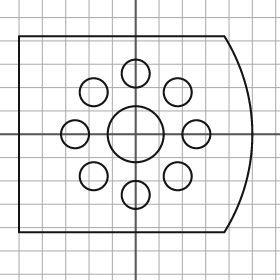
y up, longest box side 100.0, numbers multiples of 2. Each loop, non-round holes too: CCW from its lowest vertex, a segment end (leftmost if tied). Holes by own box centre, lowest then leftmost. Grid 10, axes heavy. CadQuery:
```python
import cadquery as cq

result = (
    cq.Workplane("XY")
    .moveTo(-50.0, -42.0)
    .lineTo(38.0, -42.0)
    .threePointArc((50.0, 0.0), (38.0, 42.0))
    .lineTo(-50.0, 42.0)
    .close()
    .moveTo(0.0, -26.0)
    .circle(6.0)
    .moveTo(-18.0, -18.0)
    .circle(6.0)
    .moveTo(18.0, -18.0)
    .circle(6.0)
    .moveTo(-26.0, 0.0)
    .circle(6.0)
    .moveTo(0.0, 0.0)
    .circle(12.0)
    .moveTo(26.0, 0.0)
    .circle(6.0)
    .moveTo(-18.0, 18.0)
    .circle(6.0)
    .moveTo(18.0, 18.0)
    .circle(6.0)
    .moveTo(0.0, 26.0)
    .circle(6.0)
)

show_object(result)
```